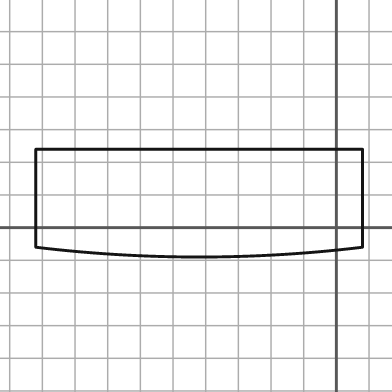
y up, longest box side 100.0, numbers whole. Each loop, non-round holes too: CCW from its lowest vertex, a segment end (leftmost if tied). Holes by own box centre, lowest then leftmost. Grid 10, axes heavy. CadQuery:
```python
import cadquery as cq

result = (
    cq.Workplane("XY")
    .moveTo(-92.0, -6.0)
    .threePointArc((-42.0, -9.0), (8.0, -6.0))
    .lineTo(8.0, 24.0)
    .lineTo(-92.0, 24.0)
    .close()
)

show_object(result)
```